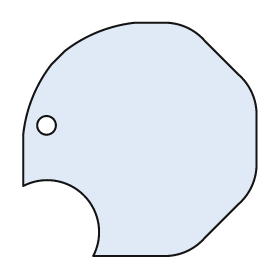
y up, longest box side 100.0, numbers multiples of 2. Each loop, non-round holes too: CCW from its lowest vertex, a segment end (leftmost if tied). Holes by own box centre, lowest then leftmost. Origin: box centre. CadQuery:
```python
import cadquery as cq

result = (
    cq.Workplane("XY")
    .moveTo(-20.0, -50.0)
    .lineTo(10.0, -50.0)
    .threePointArc((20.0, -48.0), (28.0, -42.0))
    .lineTo(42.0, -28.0)
    .threePointArc((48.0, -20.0), (50.0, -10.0))
    .lineTo(50.0, 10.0)
    .threePointArc((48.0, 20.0), (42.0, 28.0))
    .lineTo(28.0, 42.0)
    .threePointArc((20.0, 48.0), (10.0, 50.0))
    .lineTo(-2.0, 50.0)
    .threePointArc((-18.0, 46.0), (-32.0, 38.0))
    .lineTo(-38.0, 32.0)
    .threePointArc((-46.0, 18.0), (-50.0, 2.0))
    .lineTo(-50.0, -20.0)
    .threePointArc((-24.0, -24.0), (-20.0, -50.0))
    .close()
    .moveTo(-40.0, 6.0)
    .circle(4.0)
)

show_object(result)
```